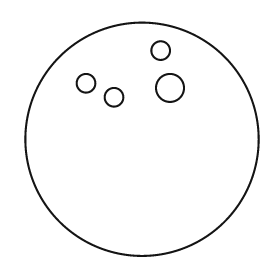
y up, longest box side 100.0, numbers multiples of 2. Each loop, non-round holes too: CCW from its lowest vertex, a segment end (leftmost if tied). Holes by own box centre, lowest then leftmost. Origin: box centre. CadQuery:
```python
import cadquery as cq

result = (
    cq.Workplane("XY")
    .moveTo(0.0, 0.0)
    .circle(50.0)
    .moveTo(-12.0, 18.0)
    .circle(4.0)
    .moveTo(12.0, 22.0)
    .circle(6.0)
    .moveTo(-24.0, 24.0)
    .circle(4.0)
    .moveTo(8.0, 38.0)
    .circle(4.0)
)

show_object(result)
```